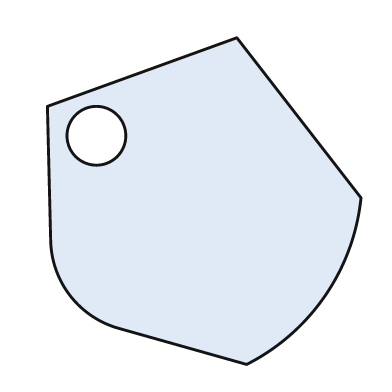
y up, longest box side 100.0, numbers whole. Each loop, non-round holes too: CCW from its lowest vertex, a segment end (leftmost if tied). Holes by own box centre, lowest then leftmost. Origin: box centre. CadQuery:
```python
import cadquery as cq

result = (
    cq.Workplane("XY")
    .moveTo(13.0, -50.0)
    .threePointArc((37.0, -29.0), (48.0, 1.0))
    .lineTo(10.0, 50.0)
    .lineTo(-48.0, 29.0)
    .lineTo(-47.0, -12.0)
    .threePointArc((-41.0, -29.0), (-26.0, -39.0))
    .close()
    .moveTo(-33.0, 20.0)
    .circle(9.0)
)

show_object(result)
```